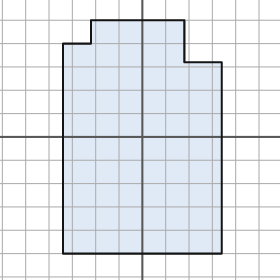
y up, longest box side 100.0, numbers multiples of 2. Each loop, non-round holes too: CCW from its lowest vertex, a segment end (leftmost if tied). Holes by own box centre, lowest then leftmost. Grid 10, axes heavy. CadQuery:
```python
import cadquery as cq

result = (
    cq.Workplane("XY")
    .moveTo(-34.0, -50.0)
    .lineTo(34.0, -50.0)
    .lineTo(34.0, 32.0)
    .lineTo(18.0, 32.0)
    .lineTo(18.0, 50.0)
    .lineTo(-22.0, 50.0)
    .lineTo(-22.0, 40.0)
    .lineTo(-34.0, 40.0)
    .close()
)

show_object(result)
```